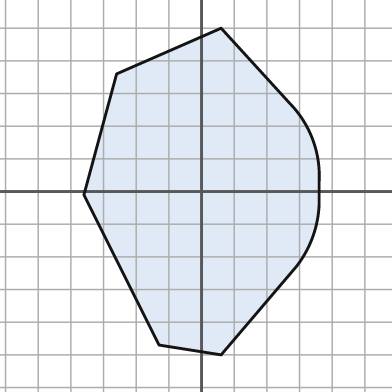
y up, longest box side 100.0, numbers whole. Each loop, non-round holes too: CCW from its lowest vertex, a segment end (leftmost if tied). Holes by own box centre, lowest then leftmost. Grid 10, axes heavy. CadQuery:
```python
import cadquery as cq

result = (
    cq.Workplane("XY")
    .moveTo(6.0, -50.0)
    .lineTo(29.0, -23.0)
    .threePointArc((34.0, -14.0), (36.0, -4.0))
    .lineTo(36.0, 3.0)
    .threePointArc((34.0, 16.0), (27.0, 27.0))
    .lineTo(6.0, 50.0)
    .lineTo(-26.0, 36.0)
    .lineTo(-36.0, -1.0)
    .lineTo(-13.0, -47.0)
    .close()
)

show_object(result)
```